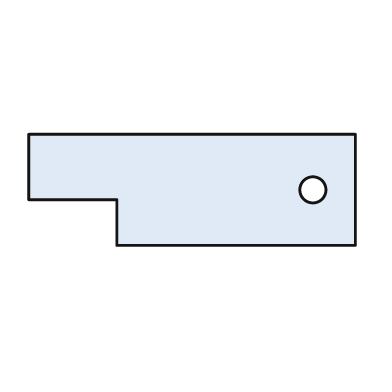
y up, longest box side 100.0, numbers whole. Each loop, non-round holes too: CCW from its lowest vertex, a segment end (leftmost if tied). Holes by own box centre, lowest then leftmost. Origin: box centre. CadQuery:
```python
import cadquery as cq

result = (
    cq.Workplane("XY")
    .moveTo(-23.0, -17.0)
    .lineTo(50.0, -17.0)
    .lineTo(50.0, 17.0)
    .lineTo(-50.0, 17.0)
    .lineTo(-50.0, -3.0)
    .lineTo(-23.0, -3.0)
    .close()
    .moveTo(37.0, 0.0)
    .circle(4.0)
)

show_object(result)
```